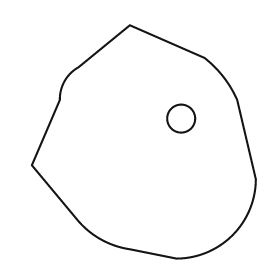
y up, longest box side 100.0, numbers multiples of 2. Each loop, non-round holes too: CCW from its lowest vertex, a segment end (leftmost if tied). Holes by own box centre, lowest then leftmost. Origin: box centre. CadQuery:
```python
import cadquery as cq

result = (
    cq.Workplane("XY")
    .moveTo(14.0, -50.0)
    .threePointArc((38.0, -40.0), (48.0, -16.0))
    .lineTo(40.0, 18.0)
    .threePointArc((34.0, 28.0), (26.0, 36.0))
    .lineTo(-6.0, 50.0)
    .lineTo(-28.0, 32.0)
    .threePointArc((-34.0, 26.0), (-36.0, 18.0))
    .lineTo(-48.0, -10.0)
    .lineTo(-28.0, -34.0)
    .threePointArc((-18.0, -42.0), (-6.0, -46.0))
    .close()
    .moveTo(16.0, 10.0)
    .circle(6.0)
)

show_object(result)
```